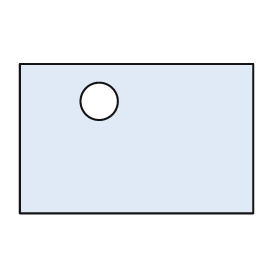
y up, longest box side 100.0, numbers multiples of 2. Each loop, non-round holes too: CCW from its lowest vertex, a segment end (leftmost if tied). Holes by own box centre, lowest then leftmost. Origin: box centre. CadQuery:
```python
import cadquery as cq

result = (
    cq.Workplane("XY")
    .moveTo(-50.0, -32.0)
    .lineTo(50.0, -32.0)
    .lineTo(50.0, 32.0)
    .lineTo(-50.0, 32.0)
    .close()
    .moveTo(-16.0, 16.0)
    .circle(8.0)
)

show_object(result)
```